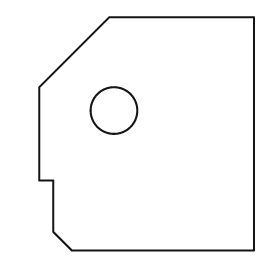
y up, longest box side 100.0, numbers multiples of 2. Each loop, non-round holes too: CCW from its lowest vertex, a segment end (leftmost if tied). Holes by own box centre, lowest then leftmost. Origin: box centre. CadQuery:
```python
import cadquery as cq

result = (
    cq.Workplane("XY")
    .moveTo(-32.0, -50.0)
    .lineTo(46.0, -50.0)
    .lineTo(46.0, 50.0)
    .lineTo(-16.0, 50.0)
    .lineTo(-46.0, 20.0)
    .lineTo(-46.0, -20.0)
    .lineTo(-40.0, -20.0)
    .lineTo(-40.0, -42.0)
    .close()
    .moveTo(-14.0, 10.0)
    .circle(10.0)
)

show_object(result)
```